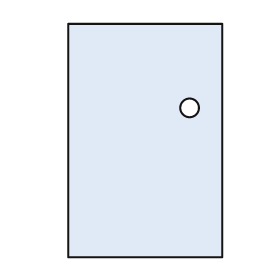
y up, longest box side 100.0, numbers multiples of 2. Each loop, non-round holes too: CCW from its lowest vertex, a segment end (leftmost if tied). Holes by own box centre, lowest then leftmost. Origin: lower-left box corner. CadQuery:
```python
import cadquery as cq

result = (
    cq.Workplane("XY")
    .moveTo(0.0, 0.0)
    .lineTo(66.0, 0.0)
    .lineTo(66.0, 100.0)
    .lineTo(0.0, 100.0)
    .close()
    .moveTo(52.0, 64.0)
    .circle(4.0)
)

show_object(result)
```